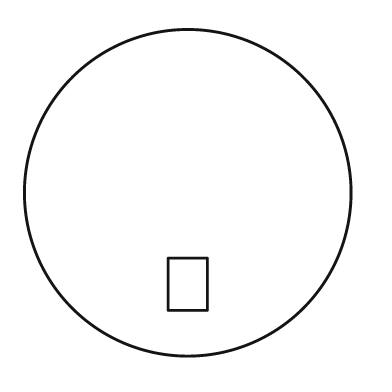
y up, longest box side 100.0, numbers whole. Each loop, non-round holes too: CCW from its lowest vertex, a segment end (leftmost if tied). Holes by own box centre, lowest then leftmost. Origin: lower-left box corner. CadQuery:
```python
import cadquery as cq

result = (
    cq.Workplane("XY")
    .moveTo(50.0, 50.0)
    .circle(50.0)
    .moveTo(44.0, 14.0)
    .lineTo(56.0, 14.0)
    .lineTo(56.0, 30.0)
    .lineTo(44.0, 30.0)
    .close()
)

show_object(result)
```